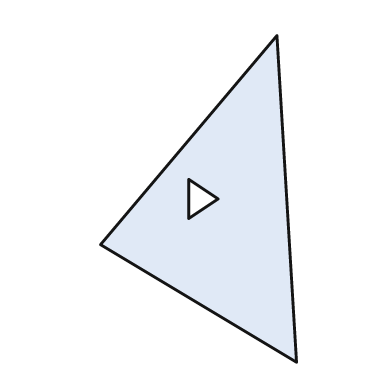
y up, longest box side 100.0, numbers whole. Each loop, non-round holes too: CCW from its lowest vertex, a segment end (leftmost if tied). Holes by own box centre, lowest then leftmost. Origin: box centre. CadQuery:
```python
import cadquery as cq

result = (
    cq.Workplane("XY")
    .moveTo(30.0, -50.0)
    .lineTo(24.0, 50.0)
    .lineTo(-30.0, -14.0)
    .close()
    .moveTo(-3.0, -6.0)
    .lineTo(6.0, 0.0)
    .lineTo(-3.0, 6.0)
    .close()
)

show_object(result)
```